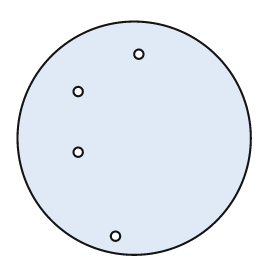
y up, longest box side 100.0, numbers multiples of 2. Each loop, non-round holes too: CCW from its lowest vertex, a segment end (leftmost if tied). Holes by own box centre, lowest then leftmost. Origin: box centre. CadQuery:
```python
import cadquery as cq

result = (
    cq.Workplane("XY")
    .moveTo(0.0, 0.0)
    .circle(50.0)
    .moveTo(-8.0, -42.0)
    .circle(2.0)
    .moveTo(-24.0, -6.0)
    .circle(2.0)
    .moveTo(-24.0, 20.0)
    .circle(2.0)
    .moveTo(2.0, 36.0)
    .circle(2.0)
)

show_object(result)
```